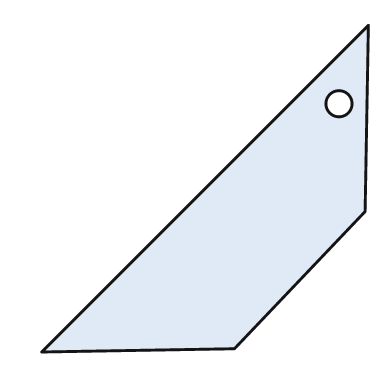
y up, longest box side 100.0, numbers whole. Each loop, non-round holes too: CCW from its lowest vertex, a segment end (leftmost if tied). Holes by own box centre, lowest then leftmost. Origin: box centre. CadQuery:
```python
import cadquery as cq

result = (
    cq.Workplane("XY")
    .moveTo(-50.0, -50.0)
    .lineTo(9.0, -49.0)
    .lineTo(49.0, -7.0)
    .lineTo(50.0, 50.0)
    .close()
    .moveTo(41.0, 26.0)
    .circle(4.0)
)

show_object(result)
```